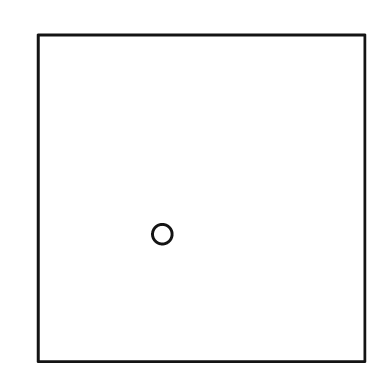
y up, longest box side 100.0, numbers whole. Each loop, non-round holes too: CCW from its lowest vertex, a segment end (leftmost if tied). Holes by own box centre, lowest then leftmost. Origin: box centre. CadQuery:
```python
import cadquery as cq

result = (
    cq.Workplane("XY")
    .moveTo(-50.0, -50.0)
    .lineTo(50.0, -50.0)
    .lineTo(50.0, 50.0)
    .lineTo(-50.0, 50.0)
    .close()
    .moveTo(-12.0, -11.0)
    .circle(3.0)
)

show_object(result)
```